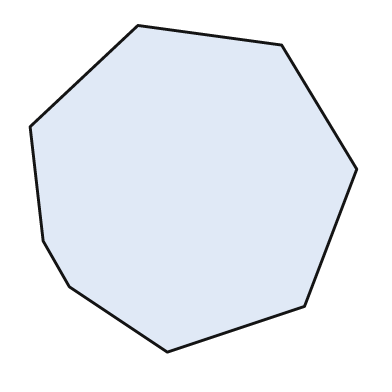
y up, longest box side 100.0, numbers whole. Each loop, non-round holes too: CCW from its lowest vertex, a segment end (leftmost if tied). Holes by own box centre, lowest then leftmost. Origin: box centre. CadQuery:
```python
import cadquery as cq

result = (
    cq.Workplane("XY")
    .moveTo(-8.0, -50.0)
    .lineTo(34.0, -36.0)
    .lineTo(50.0, 6.0)
    .lineTo(27.0, 44.0)
    .lineTo(-17.0, 50.0)
    .lineTo(-50.0, 19.0)
    .lineTo(-46.0, -16.0)
    .lineTo(-38.0, -30.0)
    .close()
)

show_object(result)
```